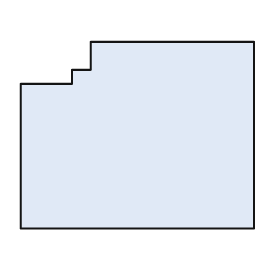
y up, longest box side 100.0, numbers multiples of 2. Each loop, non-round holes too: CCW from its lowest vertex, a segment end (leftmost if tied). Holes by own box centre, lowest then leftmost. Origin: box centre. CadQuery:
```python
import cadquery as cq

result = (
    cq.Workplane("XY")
    .moveTo(-50.0, -40.0)
    .lineTo(50.0, -40.0)
    .lineTo(50.0, 40.0)
    .lineTo(-20.0, 40.0)
    .lineTo(-20.0, 28.0)
    .lineTo(-28.0, 28.0)
    .lineTo(-28.0, 22.0)
    .lineTo(-50.0, 22.0)
    .close()
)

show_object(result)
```